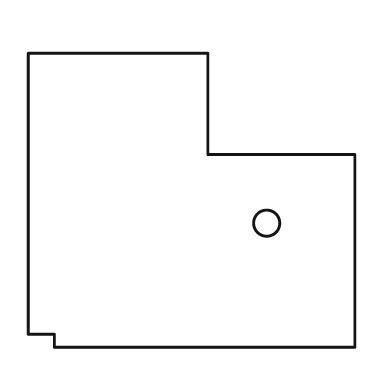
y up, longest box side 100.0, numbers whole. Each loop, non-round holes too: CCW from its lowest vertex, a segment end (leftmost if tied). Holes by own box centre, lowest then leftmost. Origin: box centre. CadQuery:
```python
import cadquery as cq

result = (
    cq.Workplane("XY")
    .moveTo(-42.0, -45.0)
    .lineTo(50.0, -45.0)
    .lineTo(50.0, 14.0)
    .lineTo(5.0, 14.0)
    .lineTo(5.0, 45.0)
    .lineTo(-50.0, 45.0)
    .lineTo(-50.0, -41.0)
    .lineTo(-42.0, -41.0)
    .close()
    .moveTo(23.0, -7.0)
    .circle(4.0)
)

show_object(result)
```